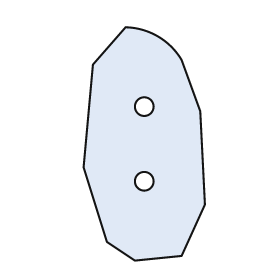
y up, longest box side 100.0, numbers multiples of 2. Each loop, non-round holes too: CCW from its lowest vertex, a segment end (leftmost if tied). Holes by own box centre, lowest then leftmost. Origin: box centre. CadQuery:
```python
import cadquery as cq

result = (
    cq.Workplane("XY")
    .moveTo(-4.0, -50.0)
    .lineTo(16.0, -48.0)
    .lineTo(26.0, -26.0)
    .lineTo(24.0, 14.0)
    .lineTo(16.0, 36.0)
    .threePointArc((6.0, 46.0), (-8.0, 50.0))
    .lineTo(-22.0, 34.0)
    .lineTo(-26.0, -10.0)
    .lineTo(-16.0, -42.0)
    .close()
    .moveTo(0.0, -16.0)
    .circle(4.0)
    .moveTo(0.0, 16.0)
    .circle(4.0)
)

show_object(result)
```